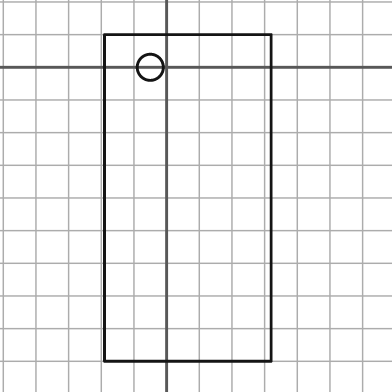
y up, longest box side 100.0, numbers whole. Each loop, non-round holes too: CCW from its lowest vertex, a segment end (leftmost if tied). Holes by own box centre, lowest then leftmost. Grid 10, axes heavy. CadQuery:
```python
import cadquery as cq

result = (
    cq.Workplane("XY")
    .moveTo(-19.0, -90.0)
    .lineTo(32.0, -90.0)
    .lineTo(32.0, 10.0)
    .lineTo(-19.0, 10.0)
    .close()
    .moveTo(-5.0, 0.0)
    .circle(4.0)
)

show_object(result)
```